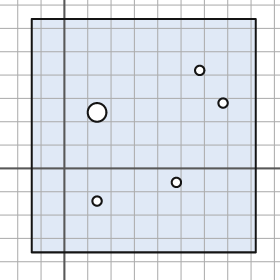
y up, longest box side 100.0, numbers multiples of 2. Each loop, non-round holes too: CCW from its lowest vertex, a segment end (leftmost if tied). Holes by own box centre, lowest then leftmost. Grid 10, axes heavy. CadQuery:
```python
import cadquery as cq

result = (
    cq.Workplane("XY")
    .moveTo(-14.0, -36.0)
    .lineTo(82.0, -36.0)
    .lineTo(82.0, 64.0)
    .lineTo(-14.0, 64.0)
    .close()
    .moveTo(14.0, -14.0)
    .circle(2.0)
    .moveTo(48.0, -6.0)
    .circle(2.0)
    .moveTo(14.0, 24.0)
    .circle(4.0)
    .moveTo(68.0, 28.0)
    .circle(2.0)
    .moveTo(58.0, 42.0)
    .circle(2.0)
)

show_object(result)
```